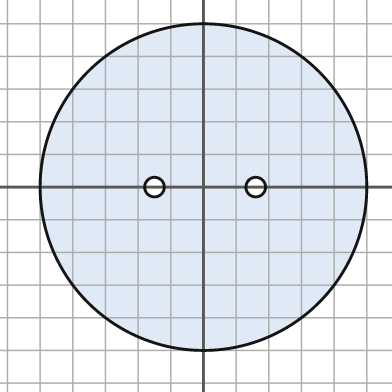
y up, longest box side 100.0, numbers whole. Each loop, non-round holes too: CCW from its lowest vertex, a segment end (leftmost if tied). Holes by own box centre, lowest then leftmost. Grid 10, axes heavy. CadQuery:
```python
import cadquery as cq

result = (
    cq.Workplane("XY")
    .moveTo(0.0, 0.0)
    .circle(50.0)
    .moveTo(-15.0, 0.0)
    .circle(3.0)
    .moveTo(16.0, 0.0)
    .circle(3.0)
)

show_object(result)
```